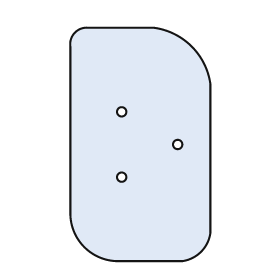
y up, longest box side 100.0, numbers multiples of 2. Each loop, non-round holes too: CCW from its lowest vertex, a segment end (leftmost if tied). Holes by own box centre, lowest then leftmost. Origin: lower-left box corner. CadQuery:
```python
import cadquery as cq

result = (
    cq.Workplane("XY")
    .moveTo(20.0, 0.0)
    .lineTo(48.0, 0.0)
    .threePointArc((56.0, 4.0), (60.0, 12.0))
    .lineTo(60.0, 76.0)
    .threePointArc((52.0, 92.0), (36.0, 100.0))
    .lineTo(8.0, 100.0)
    .threePointArc((2.0, 98.0), (0.0, 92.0))
    .lineTo(0.0, 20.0)
    .threePointArc((6.0, 6.0), (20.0, 0.0))
    .close()
    .moveTo(22.0, 36.0)
    .circle(2.0)
    .moveTo(46.0, 50.0)
    .circle(2.0)
    .moveTo(22.0, 64.0)
    .circle(2.0)
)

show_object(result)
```